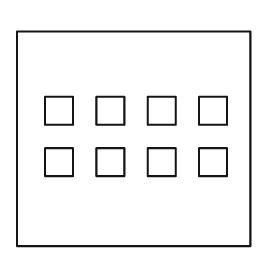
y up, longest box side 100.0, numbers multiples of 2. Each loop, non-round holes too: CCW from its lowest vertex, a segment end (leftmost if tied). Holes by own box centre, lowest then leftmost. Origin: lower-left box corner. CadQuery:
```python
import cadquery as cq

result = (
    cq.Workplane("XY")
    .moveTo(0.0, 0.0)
    .lineTo(100.0, 0.0)
    .lineTo(100.0, 92.0)
    .lineTo(0.0, 92.0)
    .close()
    .moveTo(12.0, 30.0)
    .lineTo(24.0, 30.0)
    .lineTo(24.0, 42.0)
    .lineTo(12.0, 42.0)
    .close()
    .moveTo(34.0, 30.0)
    .lineTo(46.0, 30.0)
    .lineTo(46.0, 42.0)
    .lineTo(34.0, 42.0)
    .close()
    .moveTo(56.0, 30.0)
    .lineTo(68.0, 30.0)
    .lineTo(68.0, 42.0)
    .lineTo(56.0, 42.0)
    .close()
    .moveTo(78.0, 30.0)
    .lineTo(90.0, 30.0)
    .lineTo(90.0, 42.0)
    .lineTo(78.0, 42.0)
    .close()
    .moveTo(12.0, 52.0)
    .lineTo(24.0, 52.0)
    .lineTo(24.0, 64.0)
    .lineTo(12.0, 64.0)
    .close()
    .moveTo(34.0, 52.0)
    .lineTo(46.0, 52.0)
    .lineTo(46.0, 64.0)
    .lineTo(34.0, 64.0)
    .close()
    .moveTo(56.0, 52.0)
    .lineTo(68.0, 52.0)
    .lineTo(68.0, 64.0)
    .lineTo(56.0, 64.0)
    .close()
    .moveTo(78.0, 52.0)
    .lineTo(90.0, 52.0)
    .lineTo(90.0, 64.0)
    .lineTo(78.0, 64.0)
    .close()
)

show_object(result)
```